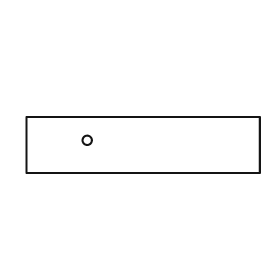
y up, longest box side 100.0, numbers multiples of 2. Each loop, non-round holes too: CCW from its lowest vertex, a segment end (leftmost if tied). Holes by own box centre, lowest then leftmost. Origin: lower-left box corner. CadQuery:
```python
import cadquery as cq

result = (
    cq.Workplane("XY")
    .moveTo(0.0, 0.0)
    .lineTo(100.0, 0.0)
    .lineTo(100.0, 24.0)
    .lineTo(0.0, 24.0)
    .close()
    .moveTo(26.0, 14.0)
    .circle(2.0)
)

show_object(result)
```